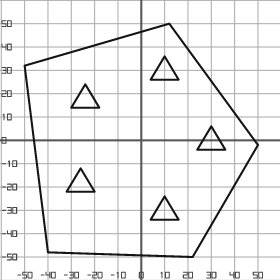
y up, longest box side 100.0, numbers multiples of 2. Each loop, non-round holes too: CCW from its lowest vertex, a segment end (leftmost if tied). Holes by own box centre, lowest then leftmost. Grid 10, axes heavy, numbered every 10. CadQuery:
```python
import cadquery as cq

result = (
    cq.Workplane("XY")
    .moveTo(22.0, -50.0)
    .lineTo(50.0, -2.0)
    .lineTo(12.0, 50.0)
    .lineTo(-50.0, 32.0)
    .lineTo(-40.0, -48.0)
    .close()
    .moveTo(4.0, -34.0)
    .lineTo(16.0, -34.0)
    .lineTo(10.0, -24.0)
    .close()
    .moveTo(-32.0, -22.0)
    .lineTo(-20.0, -22.0)
    .lineTo(-26.0, -12.0)
    .close()
    .moveTo(24.0, -4.0)
    .lineTo(36.0, -4.0)
    .lineTo(30.0, 6.0)
    .close()
    .moveTo(-30.0, 14.0)
    .lineTo(-18.0, 14.0)
    .lineTo(-24.0, 24.0)
    .close()
    .moveTo(4.0, 26.0)
    .lineTo(16.0, 26.0)
    .lineTo(10.0, 36.0)
    .close()
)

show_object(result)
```